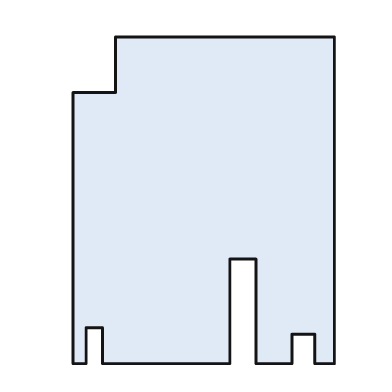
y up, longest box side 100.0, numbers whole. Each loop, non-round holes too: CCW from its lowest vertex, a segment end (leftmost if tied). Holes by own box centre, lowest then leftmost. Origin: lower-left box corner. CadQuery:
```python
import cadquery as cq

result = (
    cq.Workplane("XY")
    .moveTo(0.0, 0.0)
    .lineTo(4.0, 0.0)
    .lineTo(4.0, 11.0)
    .lineTo(9.0, 11.0)
    .lineTo(9.0, 0.0)
    .lineTo(48.0, 0.0)
    .lineTo(48.0, 32.0)
    .lineTo(56.0, 32.0)
    .lineTo(56.0, 0.0)
    .lineTo(67.0, 0.0)
    .lineTo(67.0, 9.0)
    .lineTo(74.0, 9.0)
    .lineTo(74.0, 0.0)
    .lineTo(80.0, 0.0)
    .lineTo(80.0, 100.0)
    .lineTo(13.0, 100.0)
    .lineTo(13.0, 83.0)
    .lineTo(0.0, 83.0)
    .close()
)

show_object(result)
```